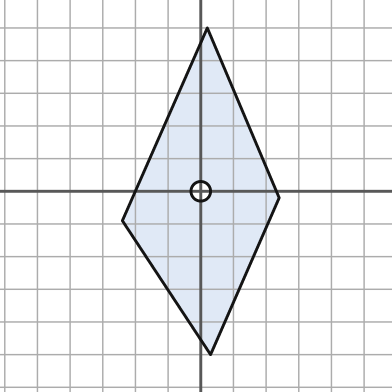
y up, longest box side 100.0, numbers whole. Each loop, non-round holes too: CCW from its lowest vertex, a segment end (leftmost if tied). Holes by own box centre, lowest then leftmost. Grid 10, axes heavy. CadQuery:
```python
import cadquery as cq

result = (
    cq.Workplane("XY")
    .moveTo(3.0, -50.0)
    .lineTo(24.0, -2.0)
    .lineTo(2.0, 50.0)
    .lineTo(-24.0, -9.0)
    .close()
    .moveTo(0.0, 0.0)
    .circle(3.0)
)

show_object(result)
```